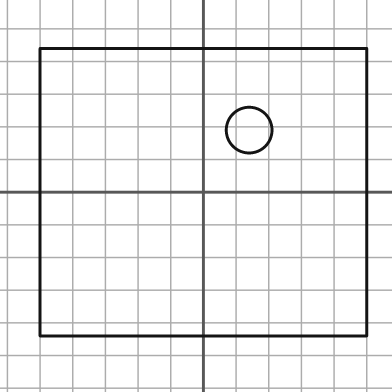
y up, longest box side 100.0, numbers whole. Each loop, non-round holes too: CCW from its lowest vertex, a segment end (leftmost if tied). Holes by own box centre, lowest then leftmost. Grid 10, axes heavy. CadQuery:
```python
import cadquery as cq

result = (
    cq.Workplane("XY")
    .moveTo(-50.0, -44.0)
    .lineTo(50.0, -44.0)
    .lineTo(50.0, 44.0)
    .lineTo(-50.0, 44.0)
    .close()
    .moveTo(14.0, 19.0)
    .circle(7.0)
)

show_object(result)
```